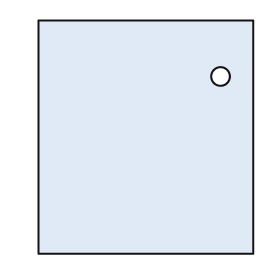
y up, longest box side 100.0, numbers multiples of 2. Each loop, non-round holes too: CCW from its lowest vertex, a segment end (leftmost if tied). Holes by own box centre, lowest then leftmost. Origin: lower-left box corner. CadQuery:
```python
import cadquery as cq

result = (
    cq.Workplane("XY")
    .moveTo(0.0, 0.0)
    .lineTo(92.0, 0.0)
    .lineTo(92.0, 100.0)
    .lineTo(0.0, 100.0)
    .close()
    .moveTo(78.0, 76.0)
    .circle(4.0)
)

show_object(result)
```